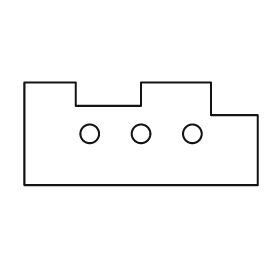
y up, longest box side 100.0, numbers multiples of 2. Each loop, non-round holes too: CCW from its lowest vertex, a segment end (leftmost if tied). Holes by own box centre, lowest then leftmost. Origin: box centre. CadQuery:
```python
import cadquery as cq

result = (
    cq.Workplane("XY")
    .moveTo(-50.0, -22.0)
    .lineTo(50.0, -22.0)
    .lineTo(50.0, 8.0)
    .lineTo(30.0, 8.0)
    .lineTo(30.0, 22.0)
    .lineTo(0.0, 22.0)
    .lineTo(0.0, 12.0)
    .lineTo(-28.0, 12.0)
    .lineTo(-28.0, 22.0)
    .lineTo(-50.0, 22.0)
    .close()
    .moveTo(-22.0, 0.0)
    .circle(4.0)
    .moveTo(0.0, 0.0)
    .circle(4.0)
    .moveTo(22.0, 0.0)
    .circle(4.0)
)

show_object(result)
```